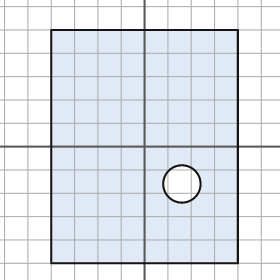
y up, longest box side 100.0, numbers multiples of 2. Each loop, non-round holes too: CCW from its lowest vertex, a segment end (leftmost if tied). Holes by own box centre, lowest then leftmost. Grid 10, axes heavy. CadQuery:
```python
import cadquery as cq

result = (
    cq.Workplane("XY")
    .moveTo(-40.0, -50.0)
    .lineTo(40.0, -50.0)
    .lineTo(40.0, 50.0)
    .lineTo(-40.0, 50.0)
    .close()
    .moveTo(16.0, -16.0)
    .circle(8.0)
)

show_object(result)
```